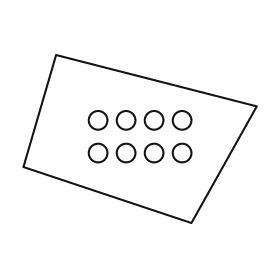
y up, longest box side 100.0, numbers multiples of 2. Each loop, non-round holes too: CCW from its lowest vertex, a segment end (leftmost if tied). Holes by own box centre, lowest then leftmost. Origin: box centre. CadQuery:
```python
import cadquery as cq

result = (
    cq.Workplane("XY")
    .moveTo(22.0, -36.0)
    .lineTo(50.0, 14.0)
    .lineTo(-36.0, 36.0)
    .lineTo(-50.0, -12.0)
    .close()
    .moveTo(-18.0, -6.0)
    .circle(4.0)
    .moveTo(-6.0, -6.0)
    .circle(4.0)
    .moveTo(6.0, -6.0)
    .circle(4.0)
    .moveTo(18.0, -6.0)
    .circle(4.0)
    .moveTo(-18.0, 8.0)
    .circle(4.0)
    .moveTo(-6.0, 8.0)
    .circle(4.0)
    .moveTo(6.0, 8.0)
    .circle(4.0)
    .moveTo(18.0, 8.0)
    .circle(4.0)
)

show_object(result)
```